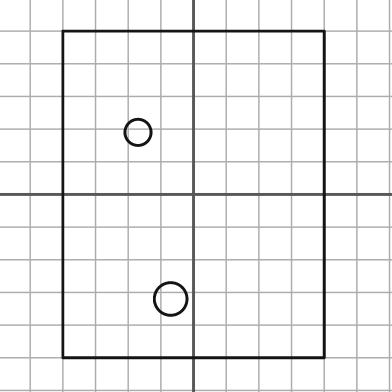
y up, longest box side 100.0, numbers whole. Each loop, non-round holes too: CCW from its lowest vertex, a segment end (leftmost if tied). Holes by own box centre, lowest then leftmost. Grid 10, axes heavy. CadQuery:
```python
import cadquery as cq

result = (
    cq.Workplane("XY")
    .moveTo(-40.0, -50.0)
    .lineTo(40.0, -50.0)
    .lineTo(40.0, 50.0)
    .lineTo(-40.0, 50.0)
    .close()
    .moveTo(-7.0, -32.0)
    .circle(5.0)
    .moveTo(-17.0, 19.0)
    .circle(4.0)
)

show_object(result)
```